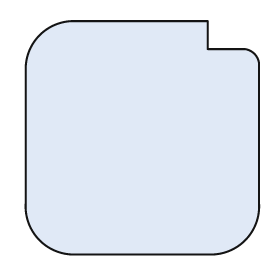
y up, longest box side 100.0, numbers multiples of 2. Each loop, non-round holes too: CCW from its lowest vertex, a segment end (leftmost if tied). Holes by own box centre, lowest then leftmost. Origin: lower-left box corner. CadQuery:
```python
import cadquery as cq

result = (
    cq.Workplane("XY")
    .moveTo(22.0, 0.0)
    .lineTo(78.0, 0.0)
    .threePointArc((94.0, 6.0), (100.0, 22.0))
    .lineTo(100.0, 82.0)
    .threePointArc((98.0, 86.0), (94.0, 88.0))
    .lineTo(78.0, 88.0)
    .lineTo(78.0, 100.0)
    .lineTo(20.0, 100.0)
    .threePointArc((6.0, 94.0), (0.0, 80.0))
    .lineTo(0.0, 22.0)
    .threePointArc((6.0, 6.0), (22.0, 0.0))
    .close()
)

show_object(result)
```